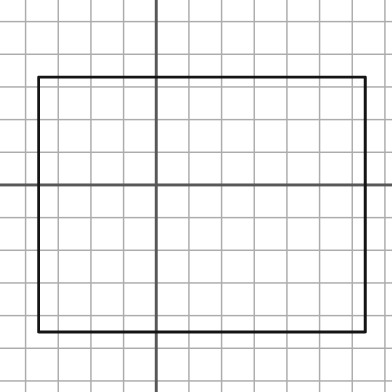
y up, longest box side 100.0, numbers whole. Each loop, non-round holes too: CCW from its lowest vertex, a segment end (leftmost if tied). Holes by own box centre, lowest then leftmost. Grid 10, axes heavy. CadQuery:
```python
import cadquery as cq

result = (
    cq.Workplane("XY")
    .moveTo(-36.0, -45.0)
    .lineTo(64.0, -45.0)
    .lineTo(64.0, 33.0)
    .lineTo(-36.0, 33.0)
    .close()
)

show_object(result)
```